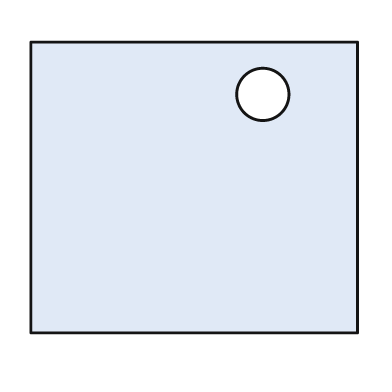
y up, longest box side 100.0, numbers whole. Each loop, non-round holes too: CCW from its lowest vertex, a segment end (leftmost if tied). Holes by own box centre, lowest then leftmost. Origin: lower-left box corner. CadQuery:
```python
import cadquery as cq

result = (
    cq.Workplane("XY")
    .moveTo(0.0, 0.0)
    .lineTo(100.0, 0.0)
    .lineTo(100.0, 89.0)
    .lineTo(0.0, 89.0)
    .close()
    .moveTo(71.0, 73.0)
    .circle(8.0)
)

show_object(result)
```